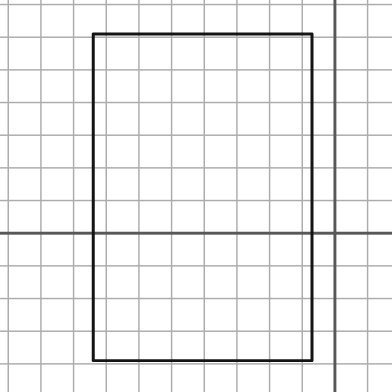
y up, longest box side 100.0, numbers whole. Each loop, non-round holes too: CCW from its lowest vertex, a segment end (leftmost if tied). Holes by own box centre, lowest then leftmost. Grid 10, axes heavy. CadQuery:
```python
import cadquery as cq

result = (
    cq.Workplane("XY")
    .moveTo(-74.0, -39.0)
    .lineTo(-7.0, -39.0)
    .lineTo(-7.0, 61.0)
    .lineTo(-74.0, 61.0)
    .close()
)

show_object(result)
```